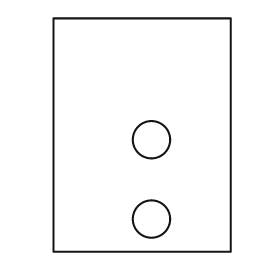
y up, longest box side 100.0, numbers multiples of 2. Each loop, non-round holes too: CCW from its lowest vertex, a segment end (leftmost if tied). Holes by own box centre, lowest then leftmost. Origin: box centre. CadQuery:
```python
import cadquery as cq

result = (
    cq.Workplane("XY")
    .moveTo(-38.0, -50.0)
    .lineTo(38.0, -50.0)
    .lineTo(38.0, 50.0)
    .lineTo(-38.0, 50.0)
    .close()
    .moveTo(4.0, -36.0)
    .circle(8.0)
    .moveTo(4.0, -2.0)
    .circle(8.0)
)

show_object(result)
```